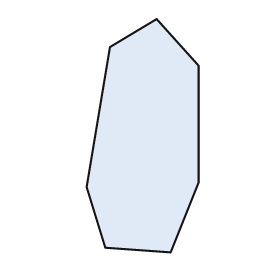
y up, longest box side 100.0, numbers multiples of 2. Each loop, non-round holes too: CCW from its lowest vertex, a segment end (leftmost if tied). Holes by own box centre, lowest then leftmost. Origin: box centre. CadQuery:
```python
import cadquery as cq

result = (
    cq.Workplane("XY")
    .moveTo(12.0, -50.0)
    .lineTo(24.0, -20.0)
    .lineTo(24.0, 30.0)
    .lineTo(6.0, 50.0)
    .lineTo(-14.0, 38.0)
    .lineTo(-24.0, -22.0)
    .lineTo(-16.0, -48.0)
    .close()
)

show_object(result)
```